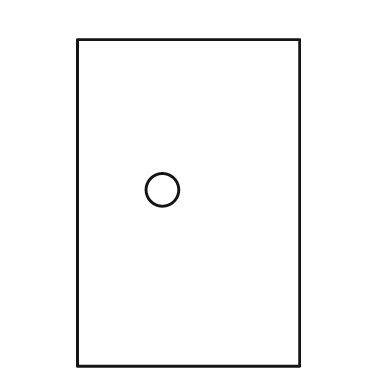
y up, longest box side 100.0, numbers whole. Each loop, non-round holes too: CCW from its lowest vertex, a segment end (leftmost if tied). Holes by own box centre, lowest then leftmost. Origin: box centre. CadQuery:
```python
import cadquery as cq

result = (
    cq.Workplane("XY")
    .moveTo(-34.0, -50.0)
    .lineTo(34.0, -50.0)
    .lineTo(34.0, 50.0)
    .lineTo(-34.0, 50.0)
    .close()
    .moveTo(-8.0, 4.0)
    .circle(5.0)
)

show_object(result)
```